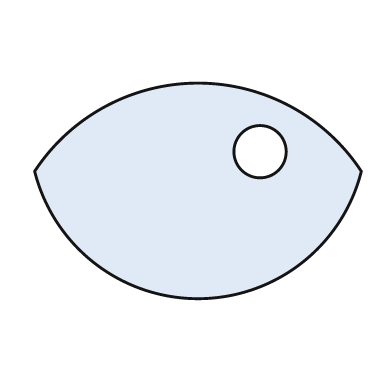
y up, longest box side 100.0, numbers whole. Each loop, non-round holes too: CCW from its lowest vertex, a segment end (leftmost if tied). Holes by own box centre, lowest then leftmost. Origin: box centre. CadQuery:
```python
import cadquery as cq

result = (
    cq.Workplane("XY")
    .moveTo(-50.0, 6.0)
    .threePointArc((0.0, -33.0), (50.0, 6.0))
    .threePointArc((0.0, 33.0), (-50.0, 6.0))
    .close()
    .moveTo(19.0, 12.0)
    .circle(8.0)
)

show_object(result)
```